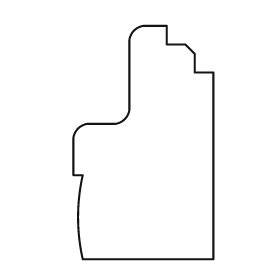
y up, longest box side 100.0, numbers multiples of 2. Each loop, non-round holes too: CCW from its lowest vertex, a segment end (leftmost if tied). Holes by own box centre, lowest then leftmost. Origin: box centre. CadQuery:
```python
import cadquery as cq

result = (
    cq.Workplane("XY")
    .moveTo(-26.0, -50.0)
    .lineTo(30.0, -50.0)
    .lineTo(30.0, 30.0)
    .lineTo(22.0, 30.0)
    .lineTo(22.0, 38.0)
    .lineTo(18.0, 42.0)
    .lineTo(10.0, 42.0)
    .lineTo(10.0, 50.0)
    .lineTo(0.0, 50.0)
    .threePointArc((-4.0, 48.0), (-6.0, 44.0))
    .lineTo(-6.0, 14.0)
    .threePointArc((-8.0, 10.0), (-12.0, 8.0))
    .lineTo(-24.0, 8.0)
    .threePointArc((-28.0, 6.0), (-30.0, 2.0))
    .lineTo(-30.0, -14.0)
    .lineTo(-26.0, -14.0)
    .threePointArc((-28.0, -32.0), (-26.0, -50.0))
    .close()
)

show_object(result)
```